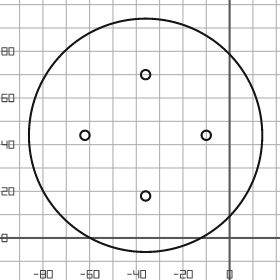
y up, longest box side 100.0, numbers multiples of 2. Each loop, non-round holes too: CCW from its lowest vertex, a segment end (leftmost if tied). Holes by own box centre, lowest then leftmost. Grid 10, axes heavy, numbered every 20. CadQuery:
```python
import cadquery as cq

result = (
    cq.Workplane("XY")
    .moveTo(-36.0, 44.0)
    .circle(50.0)
    .moveTo(-36.0, 18.0)
    .circle(2.0)
    .moveTo(-62.0, 44.0)
    .circle(2.0)
    .moveTo(-10.0, 44.0)
    .circle(2.0)
    .moveTo(-36.0, 70.0)
    .circle(2.0)
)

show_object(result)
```